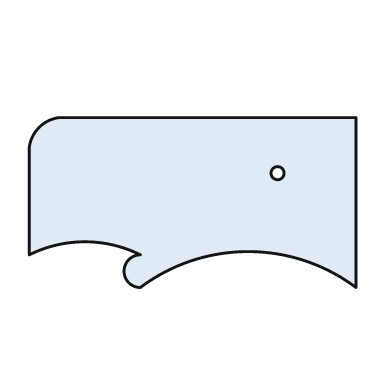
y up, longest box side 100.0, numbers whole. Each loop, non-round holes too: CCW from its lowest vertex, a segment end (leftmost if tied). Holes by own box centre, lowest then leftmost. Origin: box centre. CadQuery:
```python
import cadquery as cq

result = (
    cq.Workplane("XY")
    .moveTo(-16.0, -26.0)
    .threePointArc((17.0, -15.0), (50.0, -26.0))
    .lineTo(50.0, 26.0)
    .lineTo(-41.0, 26.0)
    .threePointArc((-47.0, 23.0), (-50.0, 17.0))
    .lineTo(-50.0, -16.0)
    .threePointArc((-33.0, -12.0), (-16.0, -16.0))
    .threePointArc((-21.0, -21.0), (-16.0, -26.0))
    .close()
    .moveTo(26.0, 9.0)
    .circle(2.0)
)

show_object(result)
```